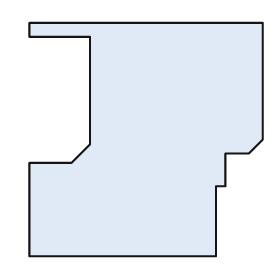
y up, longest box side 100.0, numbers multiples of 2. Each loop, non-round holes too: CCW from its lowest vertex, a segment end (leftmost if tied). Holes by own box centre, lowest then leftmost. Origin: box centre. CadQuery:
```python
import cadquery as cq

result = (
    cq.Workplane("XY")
    .moveTo(-50.0, -50.0)
    .lineTo(30.0, -50.0)
    .lineTo(30.0, -20.0)
    .lineTo(34.0, -20.0)
    .lineTo(34.0, -6.0)
    .lineTo(44.0, -6.0)
    .lineTo(50.0, 0.0)
    .lineTo(50.0, 50.0)
    .lineTo(-50.0, 50.0)
    .lineTo(-50.0, 44.0)
    .lineTo(-24.0, 44.0)
    .lineTo(-24.0, -2.0)
    .lineTo(-32.0, -10.0)
    .lineTo(-50.0, -10.0)
    .close()
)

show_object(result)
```